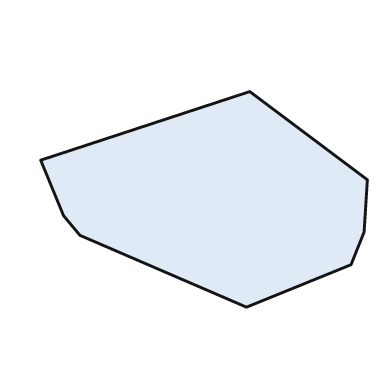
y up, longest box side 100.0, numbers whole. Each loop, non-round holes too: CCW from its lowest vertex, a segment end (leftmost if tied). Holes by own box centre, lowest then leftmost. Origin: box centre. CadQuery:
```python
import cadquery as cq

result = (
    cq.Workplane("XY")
    .moveTo(13.0, -33.0)
    .lineTo(45.0, -20.0)
    .lineTo(49.0, -10.0)
    .lineTo(50.0, 6.0)
    .lineTo(14.0, 33.0)
    .lineTo(-50.0, 12.0)
    .lineTo(-43.0, -5.0)
    .lineTo(-38.0, -11.0)
    .close()
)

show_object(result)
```